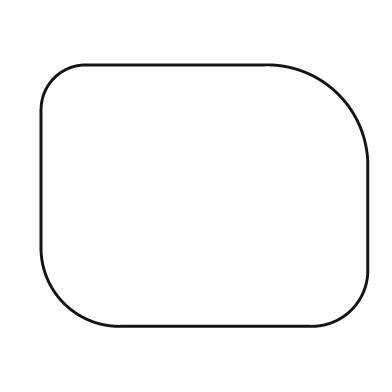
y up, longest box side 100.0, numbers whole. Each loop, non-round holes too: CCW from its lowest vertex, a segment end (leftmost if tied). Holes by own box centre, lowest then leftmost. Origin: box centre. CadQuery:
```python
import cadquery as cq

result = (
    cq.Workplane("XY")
    .moveTo(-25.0, -40.0)
    .lineTo(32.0, -40.0)
    .threePointArc((45.0, -35.0), (50.0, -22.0))
    .lineTo(50.0, 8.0)
    .threePointArc((41.0, 31.0), (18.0, 40.0))
    .lineTo(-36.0, 40.0)
    .threePointArc((-46.0, 36.0), (-50.0, 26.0))
    .lineTo(-50.0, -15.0)
    .threePointArc((-43.0, -33.0), (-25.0, -40.0))
    .close()
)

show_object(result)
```